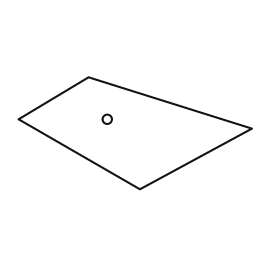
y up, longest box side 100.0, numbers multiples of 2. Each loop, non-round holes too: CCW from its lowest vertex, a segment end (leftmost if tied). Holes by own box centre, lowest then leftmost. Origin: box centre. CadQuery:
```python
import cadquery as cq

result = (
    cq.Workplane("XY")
    .moveTo(2.0, -24.0)
    .lineTo(50.0, 2.0)
    .lineTo(-20.0, 24.0)
    .lineTo(-50.0, 6.0)
    .close()
    .moveTo(-12.0, 6.0)
    .circle(2.0)
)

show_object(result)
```